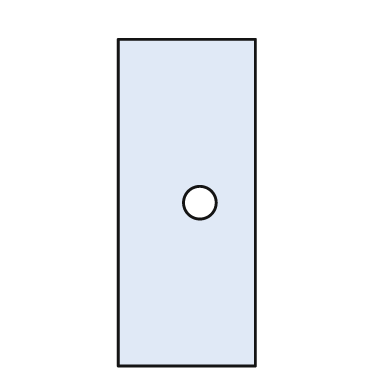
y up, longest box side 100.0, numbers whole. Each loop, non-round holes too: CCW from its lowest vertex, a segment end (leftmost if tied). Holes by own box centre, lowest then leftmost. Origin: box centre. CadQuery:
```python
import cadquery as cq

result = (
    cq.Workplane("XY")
    .moveTo(-21.0, -50.0)
    .lineTo(21.0, -50.0)
    .lineTo(21.0, 50.0)
    .lineTo(-21.0, 50.0)
    .close()
    .moveTo(4.0, 0.0)
    .circle(5.0)
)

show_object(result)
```